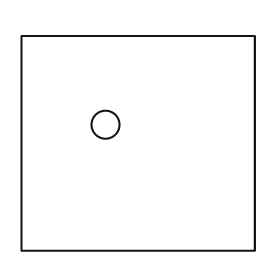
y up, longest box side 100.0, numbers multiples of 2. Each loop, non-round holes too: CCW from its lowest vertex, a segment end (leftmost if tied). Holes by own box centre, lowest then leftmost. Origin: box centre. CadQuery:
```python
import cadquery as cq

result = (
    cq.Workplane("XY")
    .moveTo(-50.0, -46.0)
    .lineTo(50.0, -46.0)
    .lineTo(50.0, 46.0)
    .lineTo(-50.0, 46.0)
    .close()
    .moveTo(-14.0, 8.0)
    .circle(6.0)
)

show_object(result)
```